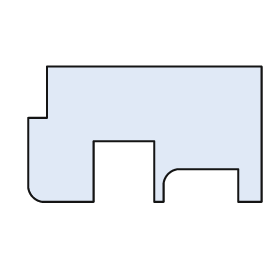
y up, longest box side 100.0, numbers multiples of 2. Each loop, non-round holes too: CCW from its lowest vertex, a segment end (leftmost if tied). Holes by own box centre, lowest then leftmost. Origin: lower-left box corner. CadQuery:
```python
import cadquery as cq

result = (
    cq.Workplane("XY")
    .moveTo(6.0, 0.0)
    .lineTo(28.0, 0.0)
    .lineTo(28.0, 26.0)
    .lineTo(54.0, 26.0)
    .lineTo(54.0, 0.0)
    .lineTo(58.0, 0.0)
    .lineTo(58.0, 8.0)
    .threePointArc((60.0, 12.0), (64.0, 14.0))
    .lineTo(90.0, 14.0)
    .lineTo(90.0, 0.0)
    .lineTo(100.0, 0.0)
    .lineTo(100.0, 58.0)
    .lineTo(8.0, 58.0)
    .lineTo(8.0, 36.0)
    .lineTo(0.0, 36.0)
    .lineTo(0.0, 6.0)
    .threePointArc((2.0, 2.0), (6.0, 0.0))
    .close()
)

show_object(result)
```